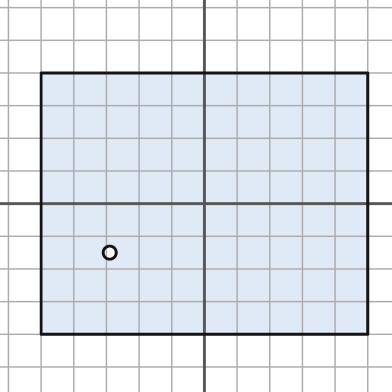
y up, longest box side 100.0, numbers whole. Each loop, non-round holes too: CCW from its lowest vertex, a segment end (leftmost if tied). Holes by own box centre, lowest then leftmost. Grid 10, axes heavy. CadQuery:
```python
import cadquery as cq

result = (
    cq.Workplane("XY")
    .moveTo(-50.0, -40.0)
    .lineTo(50.0, -40.0)
    .lineTo(50.0, 40.0)
    .lineTo(-50.0, 40.0)
    .close()
    .moveTo(-29.0, -15.0)
    .circle(2.0)
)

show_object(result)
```